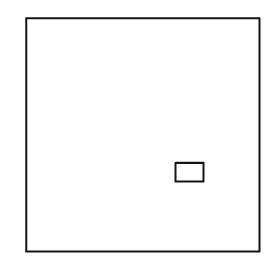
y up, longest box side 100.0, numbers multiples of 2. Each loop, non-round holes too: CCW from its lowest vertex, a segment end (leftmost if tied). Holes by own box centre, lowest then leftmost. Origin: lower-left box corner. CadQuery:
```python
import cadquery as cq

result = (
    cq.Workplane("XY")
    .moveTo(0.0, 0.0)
    .lineTo(100.0, 0.0)
    .lineTo(100.0, 100.0)
    .lineTo(0.0, 100.0)
    .close()
    .moveTo(64.0, 30.0)
    .lineTo(76.0, 30.0)
    .lineTo(76.0, 38.0)
    .lineTo(64.0, 38.0)
    .close()
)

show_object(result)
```